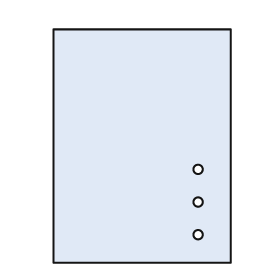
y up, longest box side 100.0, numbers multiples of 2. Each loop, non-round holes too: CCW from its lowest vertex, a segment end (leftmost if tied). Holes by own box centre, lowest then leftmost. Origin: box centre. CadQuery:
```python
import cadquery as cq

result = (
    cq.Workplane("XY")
    .moveTo(-38.0, -50.0)
    .lineTo(38.0, -50.0)
    .lineTo(38.0, 50.0)
    .lineTo(-38.0, 50.0)
    .close()
    .moveTo(24.0, -38.0)
    .circle(2.0)
    .moveTo(24.0, -24.0)
    .circle(2.0)
    .moveTo(24.0, -10.0)
    .circle(2.0)
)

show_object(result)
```